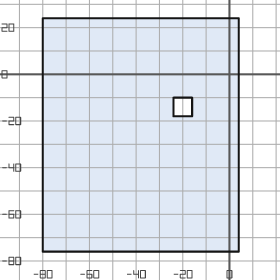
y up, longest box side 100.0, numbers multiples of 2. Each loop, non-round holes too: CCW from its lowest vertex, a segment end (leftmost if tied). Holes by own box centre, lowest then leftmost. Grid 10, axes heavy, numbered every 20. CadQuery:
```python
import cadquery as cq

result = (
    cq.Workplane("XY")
    .moveTo(-80.0, -76.0)
    .lineTo(4.0, -76.0)
    .lineTo(4.0, 24.0)
    .lineTo(-80.0, 24.0)
    .close()
    .moveTo(-24.0, -18.0)
    .lineTo(-16.0, -18.0)
    .lineTo(-16.0, -10.0)
    .lineTo(-24.0, -10.0)
    .close()
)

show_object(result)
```